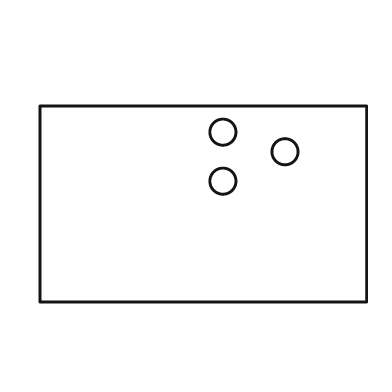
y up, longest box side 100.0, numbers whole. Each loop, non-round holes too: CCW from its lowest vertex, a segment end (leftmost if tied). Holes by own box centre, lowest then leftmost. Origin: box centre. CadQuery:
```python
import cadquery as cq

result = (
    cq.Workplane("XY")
    .moveTo(-50.0, -30.0)
    .lineTo(50.0, -30.0)
    .lineTo(50.0, 30.0)
    .lineTo(-50.0, 30.0)
    .close()
    .moveTo(6.0, 7.0)
    .circle(4.0)
    .moveTo(25.0, 16.0)
    .circle(4.0)
    .moveTo(6.0, 22.0)
    .circle(4.0)
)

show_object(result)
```